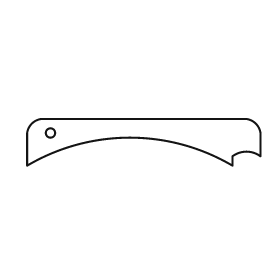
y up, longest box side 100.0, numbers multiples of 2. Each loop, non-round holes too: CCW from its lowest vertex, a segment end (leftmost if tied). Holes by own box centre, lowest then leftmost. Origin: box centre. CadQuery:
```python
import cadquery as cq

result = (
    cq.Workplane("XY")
    .moveTo(-50.0, -10.0)
    .threePointArc((-6.0, 2.0), (38.0, -10.0))
    .lineTo(38.0, -6.0)
    .threePointArc((44.0, -4.0), (50.0, -6.0))
    .lineTo(50.0, 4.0)
    .threePointArc((48.0, 8.0), (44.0, 10.0))
    .lineTo(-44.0, 10.0)
    .threePointArc((-48.0, 8.0), (-50.0, 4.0))
    .close()
    .moveTo(-40.0, 4.0)
    .circle(2.0)
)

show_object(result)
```